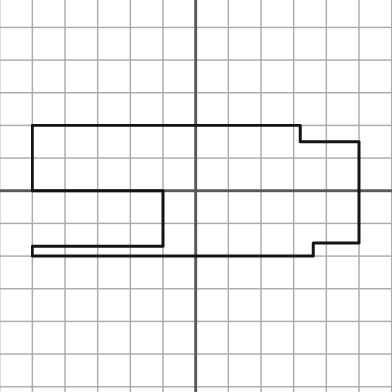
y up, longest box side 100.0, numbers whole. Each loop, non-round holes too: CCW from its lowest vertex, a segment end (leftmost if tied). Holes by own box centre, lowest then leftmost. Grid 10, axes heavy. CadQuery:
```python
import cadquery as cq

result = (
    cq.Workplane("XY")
    .moveTo(-50.0, -20.0)
    .lineTo(36.0, -20.0)
    .lineTo(36.0, -16.0)
    .lineTo(50.0, -16.0)
    .lineTo(50.0, 15.0)
    .lineTo(32.0, 15.0)
    .lineTo(32.0, 20.0)
    .lineTo(-50.0, 20.0)
    .lineTo(-50.0, 0.0)
    .lineTo(-10.0, 0.0)
    .lineTo(-10.0, -17.0)
    .lineTo(-50.0, -17.0)
    .close()
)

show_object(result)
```